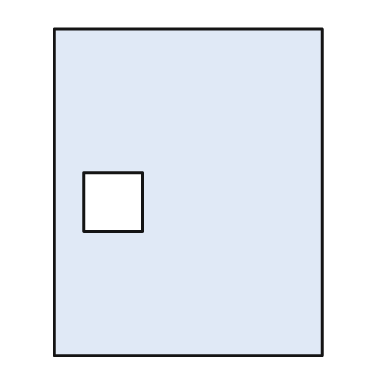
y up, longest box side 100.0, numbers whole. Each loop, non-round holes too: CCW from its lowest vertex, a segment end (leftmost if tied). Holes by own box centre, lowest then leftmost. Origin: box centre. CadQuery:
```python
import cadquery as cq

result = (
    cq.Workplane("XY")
    .moveTo(-41.0, -50.0)
    .lineTo(41.0, -50.0)
    .lineTo(41.0, 50.0)
    .lineTo(-41.0, 50.0)
    .close()
    .moveTo(-32.0, -12.0)
    .lineTo(-14.0, -12.0)
    .lineTo(-14.0, 6.0)
    .lineTo(-32.0, 6.0)
    .close()
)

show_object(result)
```